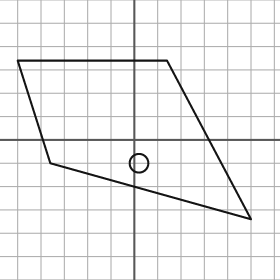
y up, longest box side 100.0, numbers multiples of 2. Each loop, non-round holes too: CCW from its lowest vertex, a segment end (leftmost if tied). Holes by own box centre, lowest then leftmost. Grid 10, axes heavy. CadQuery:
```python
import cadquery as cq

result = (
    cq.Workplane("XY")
    .moveTo(50.0, -34.0)
    .lineTo(14.0, 34.0)
    .lineTo(-50.0, 34.0)
    .lineTo(-36.0, -10.0)
    .close()
    .moveTo(2.0, -10.0)
    .circle(4.0)
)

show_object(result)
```